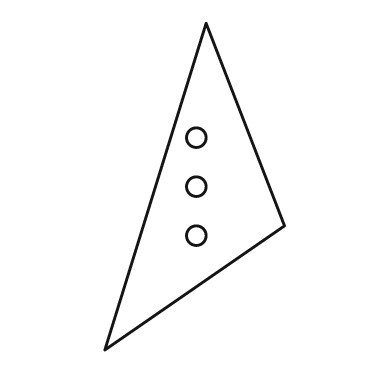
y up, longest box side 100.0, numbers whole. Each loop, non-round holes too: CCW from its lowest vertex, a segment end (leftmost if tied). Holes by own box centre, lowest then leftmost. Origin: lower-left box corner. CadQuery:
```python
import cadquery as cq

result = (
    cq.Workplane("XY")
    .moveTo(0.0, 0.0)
    .lineTo(55.0, 38.0)
    .lineTo(31.0, 100.0)
    .close()
    .moveTo(28.0, 35.0)
    .circle(3.0)
    .moveTo(28.0, 50.0)
    .circle(3.0)
    .moveTo(28.0, 65.0)
    .circle(3.0)
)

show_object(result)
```